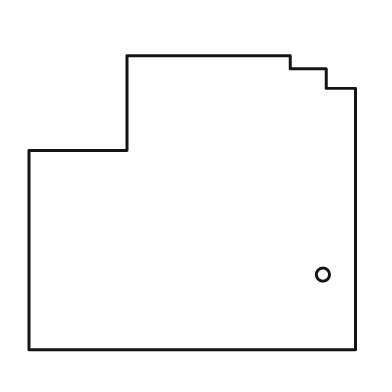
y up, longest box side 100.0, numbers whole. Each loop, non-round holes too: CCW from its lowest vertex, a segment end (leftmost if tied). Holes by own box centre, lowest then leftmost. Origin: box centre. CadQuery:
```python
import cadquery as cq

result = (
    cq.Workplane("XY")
    .moveTo(-50.0, -45.0)
    .lineTo(50.0, -45.0)
    .lineTo(50.0, 35.0)
    .lineTo(41.0, 35.0)
    .lineTo(41.0, 41.0)
    .lineTo(30.0, 41.0)
    .lineTo(30.0, 45.0)
    .lineTo(-20.0, 45.0)
    .lineTo(-20.0, 16.0)
    .lineTo(-50.0, 16.0)
    .close()
    .moveTo(40.0, -22.0)
    .circle(2.0)
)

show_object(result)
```